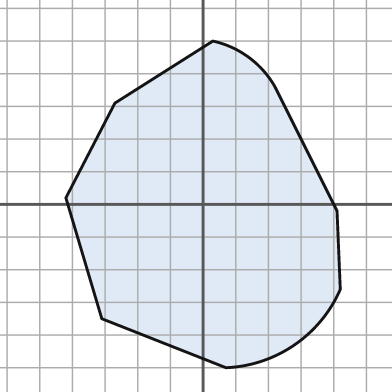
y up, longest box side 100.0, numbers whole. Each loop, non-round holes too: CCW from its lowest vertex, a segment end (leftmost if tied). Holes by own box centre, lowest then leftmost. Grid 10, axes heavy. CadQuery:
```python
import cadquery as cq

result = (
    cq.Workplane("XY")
    .moveTo(7.0, -50.0)
    .threePointArc((28.0, -43.0), (42.0, -26.0))
    .lineTo(41.0, -2.0)
    .lineTo(22.0, 36.0)
    .threePointArc((14.0, 45.0), (3.0, 50.0))
    .lineTo(-27.0, 31.0)
    .lineTo(-42.0, 2.0)
    .lineTo(-31.0, -35.0)
    .close()
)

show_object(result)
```